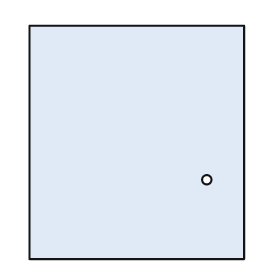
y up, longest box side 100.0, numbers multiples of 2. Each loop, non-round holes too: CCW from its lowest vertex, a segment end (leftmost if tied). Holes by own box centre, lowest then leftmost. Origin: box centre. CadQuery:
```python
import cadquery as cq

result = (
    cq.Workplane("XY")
    .moveTo(-46.0, -50.0)
    .lineTo(46.0, -50.0)
    .lineTo(46.0, 50.0)
    .lineTo(-46.0, 50.0)
    .close()
    .moveTo(30.0, -16.0)
    .circle(2.0)
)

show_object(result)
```